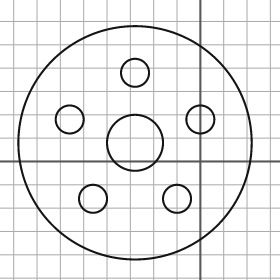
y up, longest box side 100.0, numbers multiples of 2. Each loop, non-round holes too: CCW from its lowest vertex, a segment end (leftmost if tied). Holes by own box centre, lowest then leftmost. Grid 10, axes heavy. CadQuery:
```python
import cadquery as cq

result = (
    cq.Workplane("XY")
    .moveTo(-28.0, 8.0)
    .circle(50.0)
    .moveTo(-46.0, -16.0)
    .circle(6.0)
    .moveTo(-10.0, -16.0)
    .circle(6.0)
    .moveTo(-28.0, 8.0)
    .circle(12.0)
    .moveTo(-56.0, 18.0)
    .circle(6.0)
    .moveTo(0.0, 18.0)
    .circle(6.0)
    .moveTo(-28.0, 38.0)
    .circle(6.0)
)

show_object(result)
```